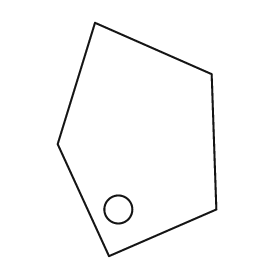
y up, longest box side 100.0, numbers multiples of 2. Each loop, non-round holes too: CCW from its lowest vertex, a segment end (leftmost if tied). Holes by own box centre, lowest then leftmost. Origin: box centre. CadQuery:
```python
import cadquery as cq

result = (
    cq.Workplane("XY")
    .moveTo(-12.0, -50.0)
    .lineTo(34.0, -30.0)
    .lineTo(32.0, 28.0)
    .lineTo(-18.0, 50.0)
    .lineTo(-34.0, -2.0)
    .close()
    .moveTo(-8.0, -30.0)
    .circle(6.0)
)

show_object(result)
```